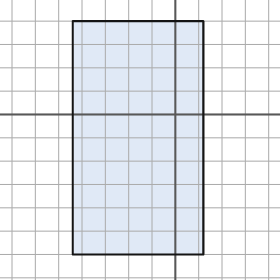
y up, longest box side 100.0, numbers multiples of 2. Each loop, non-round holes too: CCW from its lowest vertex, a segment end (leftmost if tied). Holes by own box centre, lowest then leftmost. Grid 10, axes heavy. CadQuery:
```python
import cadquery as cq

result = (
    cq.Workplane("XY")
    .moveTo(-44.0, -60.0)
    .lineTo(12.0, -60.0)
    .lineTo(12.0, 40.0)
    .lineTo(-44.0, 40.0)
    .close()
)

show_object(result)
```